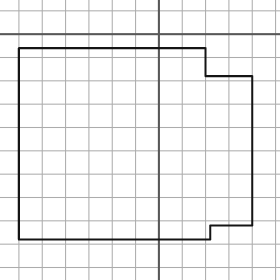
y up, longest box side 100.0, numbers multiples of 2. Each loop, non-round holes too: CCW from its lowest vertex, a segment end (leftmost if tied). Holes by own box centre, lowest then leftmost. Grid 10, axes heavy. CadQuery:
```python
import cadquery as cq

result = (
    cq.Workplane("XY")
    .moveTo(-60.0, -88.0)
    .lineTo(22.0, -88.0)
    .lineTo(22.0, -82.0)
    .lineTo(40.0, -82.0)
    .lineTo(40.0, -18.0)
    .lineTo(20.0, -18.0)
    .lineTo(20.0, -6.0)
    .lineTo(-60.0, -6.0)
    .close()
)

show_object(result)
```